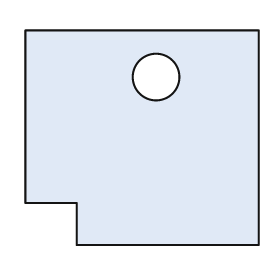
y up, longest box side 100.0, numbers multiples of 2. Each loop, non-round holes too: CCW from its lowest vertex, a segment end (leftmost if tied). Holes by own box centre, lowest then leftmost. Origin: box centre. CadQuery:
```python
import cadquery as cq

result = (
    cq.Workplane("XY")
    .moveTo(-28.0, -46.0)
    .lineTo(50.0, -46.0)
    .lineTo(50.0, 46.0)
    .lineTo(-50.0, 46.0)
    .lineTo(-50.0, -28.0)
    .lineTo(-28.0, -28.0)
    .close()
    .moveTo(6.0, 26.0)
    .circle(10.0)
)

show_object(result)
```